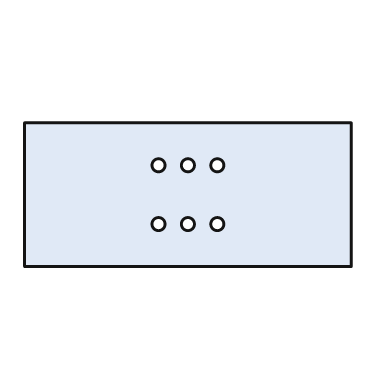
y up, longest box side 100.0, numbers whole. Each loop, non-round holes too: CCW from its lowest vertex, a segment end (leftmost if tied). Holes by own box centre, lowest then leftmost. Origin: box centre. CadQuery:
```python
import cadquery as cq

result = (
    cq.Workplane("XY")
    .moveTo(-50.0, -22.0)
    .lineTo(50.0, -22.0)
    .lineTo(50.0, 22.0)
    .lineTo(-50.0, 22.0)
    .close()
    .moveTo(-9.0, -9.0)
    .circle(2.0)
    .moveTo(0.0, -9.0)
    .circle(2.0)
    .moveTo(9.0, -9.0)
    .circle(2.0)
    .moveTo(-9.0, 9.0)
    .circle(2.0)
    .moveTo(0.0, 9.0)
    .circle(2.0)
    .moveTo(9.0, 9.0)
    .circle(2.0)
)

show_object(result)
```